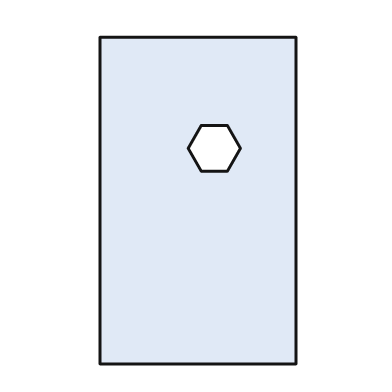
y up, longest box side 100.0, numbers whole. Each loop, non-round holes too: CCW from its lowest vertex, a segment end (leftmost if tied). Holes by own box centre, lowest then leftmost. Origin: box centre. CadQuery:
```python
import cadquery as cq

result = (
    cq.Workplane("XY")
    .moveTo(-30.0, -50.0)
    .lineTo(30.0, -50.0)
    .lineTo(30.0, 50.0)
    .lineTo(-30.0, 50.0)
    .close()
    .moveTo(1.0, 9.0)
    .lineTo(9.0, 9.0)
    .lineTo(13.0, 16.0)
    .lineTo(9.0, 23.0)
    .lineTo(1.0, 23.0)
    .lineTo(-3.0, 16.0)
    .close()
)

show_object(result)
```